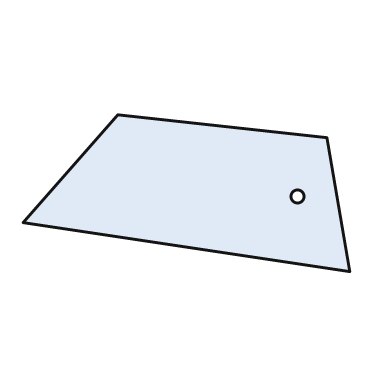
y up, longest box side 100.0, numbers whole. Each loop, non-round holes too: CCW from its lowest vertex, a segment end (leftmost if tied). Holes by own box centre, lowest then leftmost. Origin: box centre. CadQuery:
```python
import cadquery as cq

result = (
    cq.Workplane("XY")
    .moveTo(50.0, -24.0)
    .lineTo(43.0, 17.0)
    .lineTo(-21.0, 24.0)
    .lineTo(-50.0, -9.0)
    .close()
    .moveTo(34.0, -1.0)
    .circle(2.0)
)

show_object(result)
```